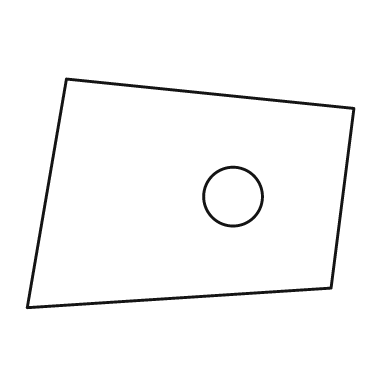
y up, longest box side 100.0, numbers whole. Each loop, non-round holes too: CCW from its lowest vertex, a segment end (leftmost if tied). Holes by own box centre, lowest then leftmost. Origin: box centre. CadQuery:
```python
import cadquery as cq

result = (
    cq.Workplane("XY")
    .moveTo(-50.0, -35.0)
    .lineTo(43.0, -29.0)
    .lineTo(50.0, 26.0)
    .lineTo(-38.0, 35.0)
    .close()
    .moveTo(13.0, -1.0)
    .circle(9.0)
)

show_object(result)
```